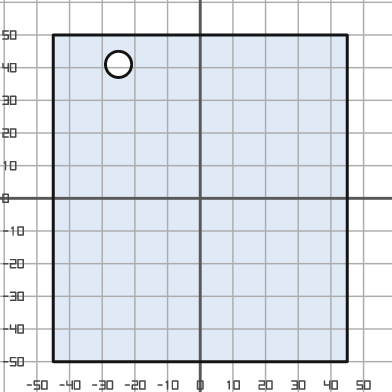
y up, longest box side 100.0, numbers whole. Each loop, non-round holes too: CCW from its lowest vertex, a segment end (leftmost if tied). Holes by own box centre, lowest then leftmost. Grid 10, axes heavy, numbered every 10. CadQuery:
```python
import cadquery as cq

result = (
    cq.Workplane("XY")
    .moveTo(-45.0, -50.0)
    .lineTo(45.0, -50.0)
    .lineTo(45.0, 50.0)
    .lineTo(-45.0, 50.0)
    .close()
    .moveTo(-25.0, 41.0)
    .circle(4.0)
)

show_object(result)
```